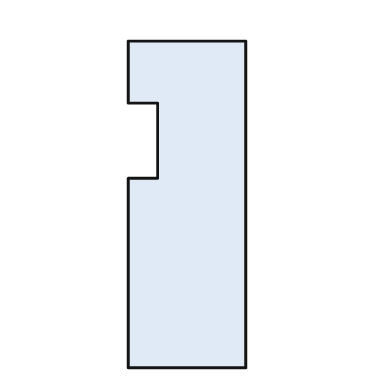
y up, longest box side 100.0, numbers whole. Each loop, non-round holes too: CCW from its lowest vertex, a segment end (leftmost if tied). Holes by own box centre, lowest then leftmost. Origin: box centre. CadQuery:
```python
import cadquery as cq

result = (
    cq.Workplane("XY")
    .moveTo(-18.0, -50.0)
    .lineTo(18.0, -50.0)
    .lineTo(18.0, 50.0)
    .lineTo(-18.0, 50.0)
    .lineTo(-18.0, 31.0)
    .lineTo(-9.0, 31.0)
    .lineTo(-9.0, 8.0)
    .lineTo(-18.0, 8.0)
    .close()
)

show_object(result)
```